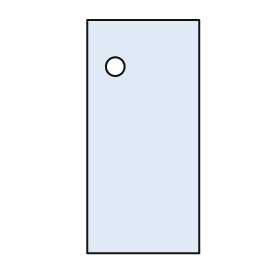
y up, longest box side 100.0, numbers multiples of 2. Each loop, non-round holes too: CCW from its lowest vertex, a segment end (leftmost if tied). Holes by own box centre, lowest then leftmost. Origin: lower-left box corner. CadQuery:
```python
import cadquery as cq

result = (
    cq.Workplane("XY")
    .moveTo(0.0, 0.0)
    .lineTo(48.0, 0.0)
    .lineTo(48.0, 100.0)
    .lineTo(0.0, 100.0)
    .close()
    .moveTo(12.0, 80.0)
    .circle(4.0)
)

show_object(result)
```